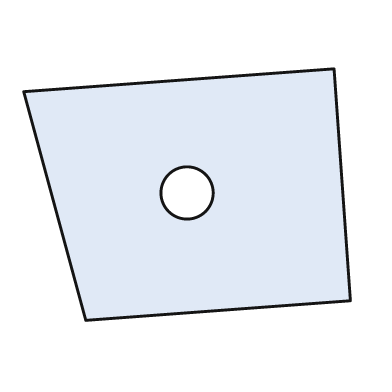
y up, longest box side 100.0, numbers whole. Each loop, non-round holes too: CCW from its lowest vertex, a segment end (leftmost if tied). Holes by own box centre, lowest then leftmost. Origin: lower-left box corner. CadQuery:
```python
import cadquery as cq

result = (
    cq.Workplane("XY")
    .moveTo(19.0, 0.0)
    .lineTo(100.0, 6.0)
    .lineTo(95.0, 77.0)
    .lineTo(0.0, 70.0)
    .close()
    .moveTo(50.0, 39.0)
    .circle(8.0)
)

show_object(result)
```